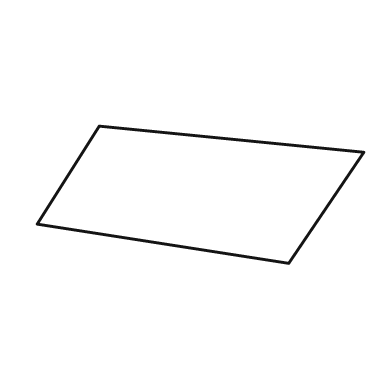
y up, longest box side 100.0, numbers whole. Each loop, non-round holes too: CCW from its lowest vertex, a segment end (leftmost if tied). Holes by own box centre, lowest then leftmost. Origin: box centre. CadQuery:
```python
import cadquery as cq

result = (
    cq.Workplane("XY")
    .moveTo(27.0, -21.0)
    .lineTo(50.0, 13.0)
    .lineTo(-31.0, 21.0)
    .lineTo(-50.0, -9.0)
    .close()
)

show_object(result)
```